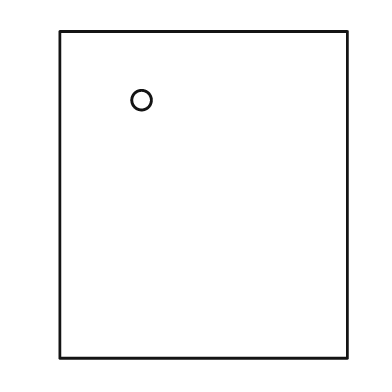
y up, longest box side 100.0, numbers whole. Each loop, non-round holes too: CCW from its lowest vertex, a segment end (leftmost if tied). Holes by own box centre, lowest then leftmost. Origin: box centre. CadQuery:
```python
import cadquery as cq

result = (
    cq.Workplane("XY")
    .moveTo(-44.0, -50.0)
    .lineTo(44.0, -50.0)
    .lineTo(44.0, 50.0)
    .lineTo(-44.0, 50.0)
    .close()
    .moveTo(-19.0, 29.0)
    .circle(3.0)
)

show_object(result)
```